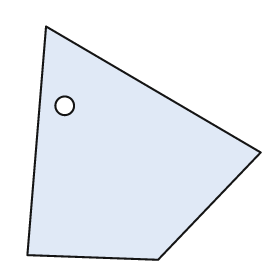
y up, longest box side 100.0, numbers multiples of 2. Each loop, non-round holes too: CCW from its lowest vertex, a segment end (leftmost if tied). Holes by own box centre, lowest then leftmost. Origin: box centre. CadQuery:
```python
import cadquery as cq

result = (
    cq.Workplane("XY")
    .moveTo(6.0, -50.0)
    .lineTo(50.0, -4.0)
    .lineTo(-42.0, 50.0)
    .lineTo(-50.0, -48.0)
    .close()
    .moveTo(-34.0, 16.0)
    .circle(4.0)
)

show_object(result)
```